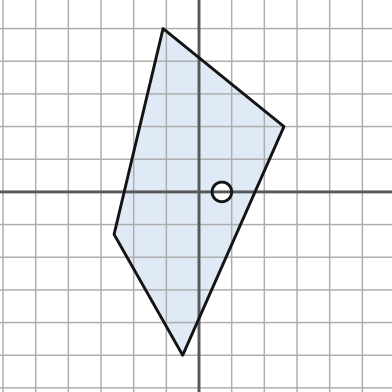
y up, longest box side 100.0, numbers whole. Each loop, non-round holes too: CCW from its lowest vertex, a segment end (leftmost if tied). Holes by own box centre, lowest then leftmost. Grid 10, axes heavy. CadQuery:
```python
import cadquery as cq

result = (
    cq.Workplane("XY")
    .moveTo(-5.0, -50.0)
    .lineTo(26.0, 20.0)
    .lineTo(-11.0, 50.0)
    .lineTo(-26.0, -13.0)
    .close()
    .moveTo(7.0, 0.0)
    .circle(3.0)
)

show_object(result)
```